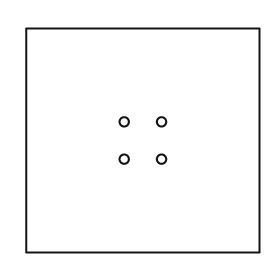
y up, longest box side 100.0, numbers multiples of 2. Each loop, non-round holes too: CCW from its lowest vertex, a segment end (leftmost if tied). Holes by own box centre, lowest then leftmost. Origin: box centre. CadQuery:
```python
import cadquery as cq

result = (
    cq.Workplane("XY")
    .moveTo(-50.0, -48.0)
    .lineTo(50.0, -48.0)
    .lineTo(50.0, 48.0)
    .lineTo(-50.0, 48.0)
    .close()
    .moveTo(-8.0, -8.0)
    .circle(2.0)
    .moveTo(8.0, -8.0)
    .circle(2.0)
    .moveTo(-8.0, 8.0)
    .circle(2.0)
    .moveTo(8.0, 8.0)
    .circle(2.0)
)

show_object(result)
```